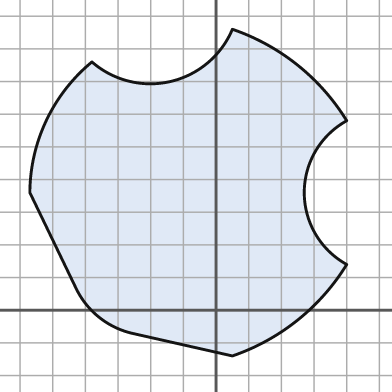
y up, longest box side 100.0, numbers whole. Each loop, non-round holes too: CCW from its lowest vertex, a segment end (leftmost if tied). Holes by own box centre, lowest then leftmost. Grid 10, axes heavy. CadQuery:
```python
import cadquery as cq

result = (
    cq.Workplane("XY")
    .moveTo(5.0, -14.0)
    .threePointArc((25.0, -3.0), (40.0, 14.0))
    .threePointArc((27.0, 36.0), (40.0, 58.0))
    .threePointArc((25.0, 75.0), (5.0, 86.0))
    .threePointArc((-14.0, 70.0), (-38.0, 76.0))
    .threePointArc((-52.0, 58.0), (-57.0, 36.0))
    .lineTo(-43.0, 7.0)
    .threePointArc((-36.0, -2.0), (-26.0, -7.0))
    .close()
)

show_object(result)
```